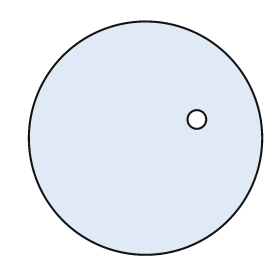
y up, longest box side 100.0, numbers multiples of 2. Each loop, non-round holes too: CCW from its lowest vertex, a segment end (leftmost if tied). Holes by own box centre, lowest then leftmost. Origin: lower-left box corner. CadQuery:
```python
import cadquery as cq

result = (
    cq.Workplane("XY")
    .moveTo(50.0, 50.0)
    .circle(50.0)
    .moveTo(72.0, 58.0)
    .circle(4.0)
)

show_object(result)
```